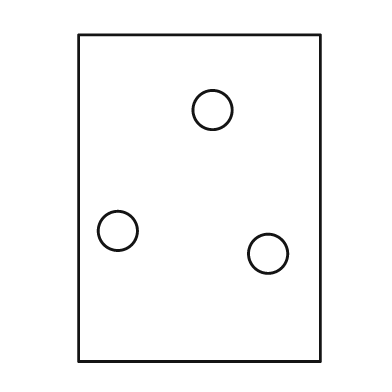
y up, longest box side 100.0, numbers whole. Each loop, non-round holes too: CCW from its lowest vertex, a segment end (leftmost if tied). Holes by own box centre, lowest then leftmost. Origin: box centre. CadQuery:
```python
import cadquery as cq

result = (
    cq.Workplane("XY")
    .moveTo(-37.0, -50.0)
    .lineTo(37.0, -50.0)
    .lineTo(37.0, 50.0)
    .lineTo(-37.0, 50.0)
    .close()
    .moveTo(21.0, -17.0)
    .circle(6.0)
    .moveTo(-25.0, -10.0)
    .circle(6.0)
    .moveTo(4.0, 27.0)
    .circle(6.0)
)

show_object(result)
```